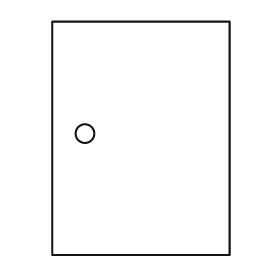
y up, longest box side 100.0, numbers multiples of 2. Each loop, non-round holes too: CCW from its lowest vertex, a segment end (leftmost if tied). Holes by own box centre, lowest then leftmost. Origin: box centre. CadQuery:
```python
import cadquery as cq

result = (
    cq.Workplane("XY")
    .moveTo(-38.0, -50.0)
    .lineTo(38.0, -50.0)
    .lineTo(38.0, 50.0)
    .lineTo(-38.0, 50.0)
    .close()
    .moveTo(-24.0, 2.0)
    .circle(4.0)
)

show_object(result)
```